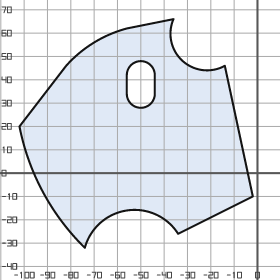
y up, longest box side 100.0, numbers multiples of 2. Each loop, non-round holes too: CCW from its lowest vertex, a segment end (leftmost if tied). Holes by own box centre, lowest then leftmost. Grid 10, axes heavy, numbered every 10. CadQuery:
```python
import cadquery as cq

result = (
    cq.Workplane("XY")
    .moveTo(-74.0, -32.0)
    .threePointArc((-56.0, -16.0), (-34.0, -26.0))
    .lineTo(-2.0, -10.0)
    .lineTo(-14.0, 46.0)
    .threePointArc((-32.0, 48.0), (-36.0, 66.0))
    .lineTo(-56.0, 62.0)
    .threePointArc((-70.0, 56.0), (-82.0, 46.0))
    .lineTo(-102.0, 20.0)
    .threePointArc((-92.0, -8.0), (-74.0, -32.0))
    .close()
    .moveTo(-56.0, 34.0)
    .threePointArc((-50.0, 28.0), (-44.0, 34.0))
    .lineTo(-44.0, 42.0)
    .threePointArc((-50.0, 48.0), (-56.0, 42.0))
    .close()
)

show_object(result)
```